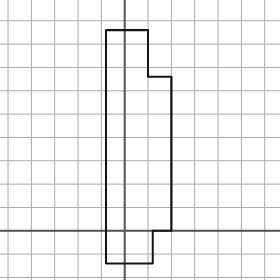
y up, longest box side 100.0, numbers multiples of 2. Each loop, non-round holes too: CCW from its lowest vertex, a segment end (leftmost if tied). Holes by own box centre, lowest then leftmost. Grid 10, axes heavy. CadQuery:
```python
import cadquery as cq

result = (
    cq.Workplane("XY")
    .moveTo(-8.0, -14.0)
    .lineTo(12.0, -14.0)
    .lineTo(12.0, 0.0)
    .lineTo(20.0, 0.0)
    .lineTo(20.0, 66.0)
    .lineTo(10.0, 66.0)
    .lineTo(10.0, 86.0)
    .lineTo(-8.0, 86.0)
    .close()
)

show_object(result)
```